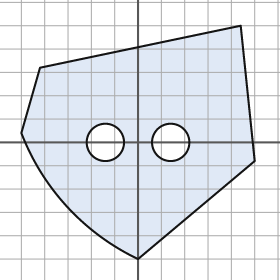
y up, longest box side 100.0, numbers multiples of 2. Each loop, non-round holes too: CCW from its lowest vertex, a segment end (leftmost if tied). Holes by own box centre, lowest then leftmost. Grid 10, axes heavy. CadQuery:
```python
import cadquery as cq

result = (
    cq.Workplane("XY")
    .moveTo(0.0, -50.0)
    .lineTo(50.0, -8.0)
    .lineTo(44.0, 50.0)
    .lineTo(-42.0, 32.0)
    .lineTo(-50.0, 4.0)
    .threePointArc((-30.0, -28.0), (0.0, -50.0))
    .close()
    .moveTo(-14.0, 0.0)
    .circle(8.0)
    .moveTo(14.0, 0.0)
    .circle(8.0)
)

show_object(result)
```